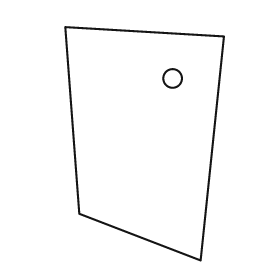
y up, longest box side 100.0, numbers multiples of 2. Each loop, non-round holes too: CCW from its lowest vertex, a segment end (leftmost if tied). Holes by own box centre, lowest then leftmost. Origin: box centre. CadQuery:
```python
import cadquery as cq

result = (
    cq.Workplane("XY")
    .moveTo(24.0, -50.0)
    .lineTo(34.0, 46.0)
    .lineTo(-34.0, 50.0)
    .lineTo(-28.0, -30.0)
    .close()
    .moveTo(12.0, 28.0)
    .circle(4.0)
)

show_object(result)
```